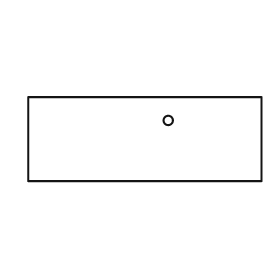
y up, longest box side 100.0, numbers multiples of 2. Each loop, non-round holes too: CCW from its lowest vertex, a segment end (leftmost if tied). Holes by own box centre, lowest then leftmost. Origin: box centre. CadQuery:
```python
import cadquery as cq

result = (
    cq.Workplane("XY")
    .moveTo(-50.0, -18.0)
    .lineTo(50.0, -18.0)
    .lineTo(50.0, 18.0)
    .lineTo(-50.0, 18.0)
    .close()
    .moveTo(10.0, 8.0)
    .circle(2.0)
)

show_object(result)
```